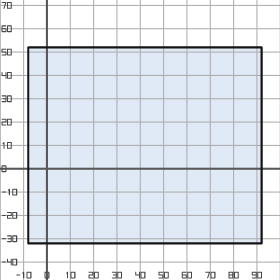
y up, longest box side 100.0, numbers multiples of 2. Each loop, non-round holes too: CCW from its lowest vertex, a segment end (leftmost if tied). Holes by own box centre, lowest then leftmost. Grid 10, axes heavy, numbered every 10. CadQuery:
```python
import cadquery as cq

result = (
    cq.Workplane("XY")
    .moveTo(-8.0, -32.0)
    .lineTo(92.0, -32.0)
    .lineTo(92.0, 52.0)
    .lineTo(-8.0, 52.0)
    .close()
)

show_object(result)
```